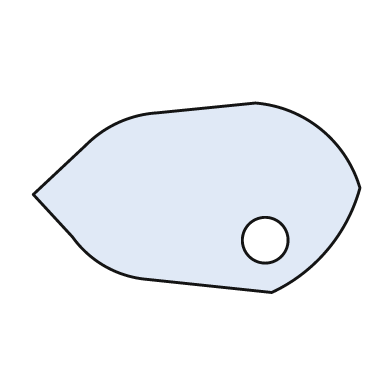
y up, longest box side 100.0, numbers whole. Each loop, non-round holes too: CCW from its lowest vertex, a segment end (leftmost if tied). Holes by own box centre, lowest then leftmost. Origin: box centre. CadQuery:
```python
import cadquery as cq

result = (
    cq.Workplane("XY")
    .moveTo(23.0, -29.0)
    .threePointArc((40.0, -16.0), (50.0, 3.0))
    .threePointArc((38.0, 21.0), (18.0, 29.0))
    .lineTo(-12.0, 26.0)
    .threePointArc((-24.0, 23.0), (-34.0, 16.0))
    .lineTo(-50.0, 1.0)
    .lineTo(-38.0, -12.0)
    .threePointArc((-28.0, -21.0), (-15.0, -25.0))
    .close()
    .moveTo(21.0, -13.0)
    .circle(7.0)
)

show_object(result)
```